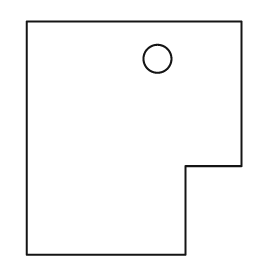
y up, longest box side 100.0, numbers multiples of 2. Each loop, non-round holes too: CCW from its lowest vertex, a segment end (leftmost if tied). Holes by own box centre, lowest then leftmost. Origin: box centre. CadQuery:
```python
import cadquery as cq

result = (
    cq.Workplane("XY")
    .moveTo(-46.0, -50.0)
    .lineTo(22.0, -50.0)
    .lineTo(22.0, -12.0)
    .lineTo(46.0, -12.0)
    .lineTo(46.0, 50.0)
    .lineTo(-46.0, 50.0)
    .close()
    .moveTo(10.0, 34.0)
    .circle(6.0)
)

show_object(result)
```